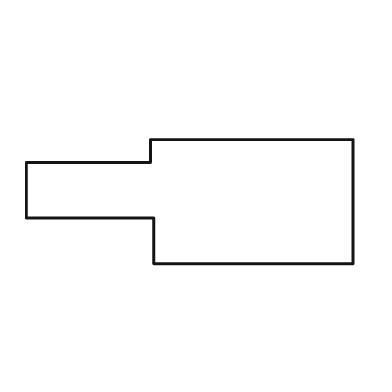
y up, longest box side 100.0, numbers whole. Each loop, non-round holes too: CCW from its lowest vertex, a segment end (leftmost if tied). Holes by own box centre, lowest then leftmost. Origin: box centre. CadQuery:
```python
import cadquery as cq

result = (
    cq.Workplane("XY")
    .moveTo(-11.0, -19.0)
    .lineTo(50.0, -19.0)
    .lineTo(50.0, 19.0)
    .lineTo(-12.0, 19.0)
    .lineTo(-12.0, 12.0)
    .lineTo(-50.0, 12.0)
    .lineTo(-50.0, -5.0)
    .lineTo(-11.0, -5.0)
    .close()
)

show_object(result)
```